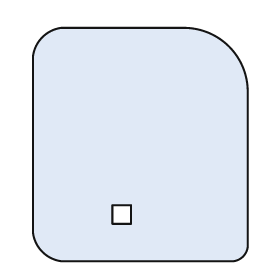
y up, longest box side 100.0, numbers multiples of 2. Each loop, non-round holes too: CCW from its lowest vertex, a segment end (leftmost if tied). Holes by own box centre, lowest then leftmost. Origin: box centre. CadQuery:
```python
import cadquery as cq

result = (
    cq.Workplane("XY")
    .moveTo(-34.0, -50.0)
    .lineTo(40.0, -50.0)
    .threePointArc((44.0, -48.0), (46.0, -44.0))
    .lineTo(46.0, 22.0)
    .threePointArc((38.0, 42.0), (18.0, 50.0))
    .lineTo(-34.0, 50.0)
    .threePointArc((-42.0, 46.0), (-46.0, 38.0))
    .lineTo(-46.0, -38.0)
    .threePointArc((-42.0, -46.0), (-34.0, -50.0))
    .close()
    .moveTo(-12.0, -34.0)
    .lineTo(-4.0, -34.0)
    .lineTo(-4.0, -26.0)
    .lineTo(-12.0, -26.0)
    .close()
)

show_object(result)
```